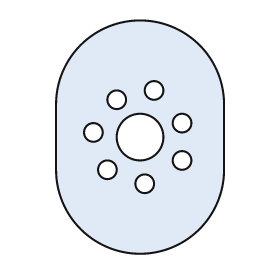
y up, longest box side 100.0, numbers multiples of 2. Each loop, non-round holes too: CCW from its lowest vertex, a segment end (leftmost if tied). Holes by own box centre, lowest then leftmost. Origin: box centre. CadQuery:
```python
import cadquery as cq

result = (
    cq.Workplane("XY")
    .moveTo(-36.0, -14.0)
    .threePointArc((0.0, -50.0), (36.0, -14.0))
    .lineTo(36.0, 14.0)
    .threePointArc((0.0, 50.0), (-36.0, 14.0))
    .close()
    .moveTo(2.0, -20.0)
    .circle(4.0)
    .moveTo(-14.0, -14.0)
    .circle(4.0)
    .moveTo(18.0, -10.0)
    .circle(4.0)
    .moveTo(0.0, 0.0)
    .circle(10.0)
    .moveTo(-20.0, 2.0)
    .circle(4.0)
    .moveTo(18.0, 6.0)
    .circle(4.0)
    .moveTo(-10.0, 16.0)
    .circle(4.0)
    .moveTo(6.0, 20.0)
    .circle(4.0)
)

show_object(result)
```